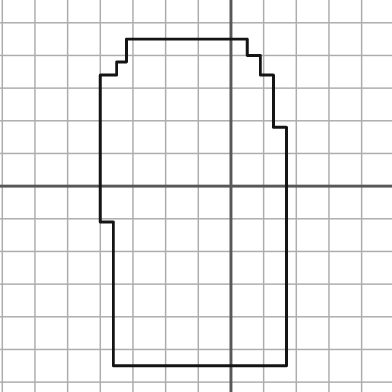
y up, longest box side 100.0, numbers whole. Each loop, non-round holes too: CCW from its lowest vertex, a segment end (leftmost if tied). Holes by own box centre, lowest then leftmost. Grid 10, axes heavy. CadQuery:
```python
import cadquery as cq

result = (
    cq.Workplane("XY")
    .moveTo(-36.0, -55.0)
    .lineTo(17.0, -55.0)
    .lineTo(17.0, 18.0)
    .lineTo(13.0, 18.0)
    .lineTo(13.0, 34.0)
    .lineTo(9.0, 34.0)
    .lineTo(9.0, 40.0)
    .lineTo(5.0, 40.0)
    .lineTo(5.0, 45.0)
    .lineTo(-32.0, 45.0)
    .lineTo(-32.0, 38.0)
    .lineTo(-35.0, 38.0)
    .lineTo(-35.0, 34.0)
    .lineTo(-40.0, 34.0)
    .lineTo(-40.0, -11.0)
    .lineTo(-36.0, -11.0)
    .close()
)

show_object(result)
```